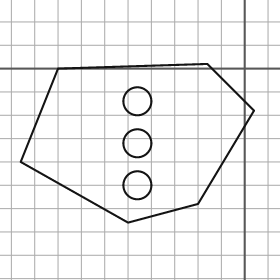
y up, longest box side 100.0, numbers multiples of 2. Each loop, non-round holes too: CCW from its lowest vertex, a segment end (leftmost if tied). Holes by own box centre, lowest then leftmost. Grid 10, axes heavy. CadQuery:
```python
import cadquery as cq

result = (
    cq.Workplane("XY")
    .moveTo(-50.0, -66.0)
    .lineTo(-20.0, -58.0)
    .lineTo(4.0, -18.0)
    .lineTo(-16.0, 2.0)
    .lineTo(-80.0, 0.0)
    .lineTo(-96.0, -40.0)
    .close()
    .moveTo(-46.0, -50.0)
    .circle(6.0)
    .moveTo(-46.0, -32.0)
    .circle(6.0)
    .moveTo(-46.0, -14.0)
    .circle(6.0)
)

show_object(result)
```